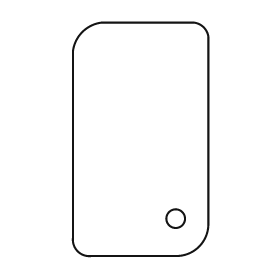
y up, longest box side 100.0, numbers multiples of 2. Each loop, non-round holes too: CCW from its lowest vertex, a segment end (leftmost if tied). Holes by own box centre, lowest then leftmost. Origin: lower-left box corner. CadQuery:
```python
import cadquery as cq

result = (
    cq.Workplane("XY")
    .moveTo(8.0, 0.0)
    .lineTo(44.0, 0.0)
    .threePointArc((54.0, 4.0), (58.0, 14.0))
    .lineTo(58.0, 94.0)
    .threePointArc((56.0, 98.0), (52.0, 100.0))
    .lineTo(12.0, 100.0)
    .threePointArc((4.0, 96.0), (0.0, 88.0))
    .lineTo(0.0, 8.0)
    .threePointArc((2.0, 2.0), (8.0, 0.0))
    .close()
    .moveTo(44.0, 16.0)
    .circle(4.0)
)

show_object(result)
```